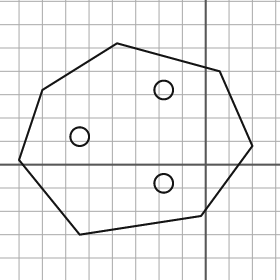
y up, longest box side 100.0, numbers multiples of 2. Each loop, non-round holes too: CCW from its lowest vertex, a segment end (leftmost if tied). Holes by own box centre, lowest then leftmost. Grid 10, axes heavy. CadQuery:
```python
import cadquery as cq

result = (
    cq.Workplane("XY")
    .moveTo(-54.0, -30.0)
    .lineTo(-2.0, -22.0)
    .lineTo(20.0, 8.0)
    .lineTo(6.0, 40.0)
    .lineTo(-38.0, 52.0)
    .lineTo(-70.0, 32.0)
    .lineTo(-80.0, 2.0)
    .close()
    .moveTo(-18.0, -8.0)
    .circle(4.0)
    .moveTo(-54.0, 12.0)
    .circle(4.0)
    .moveTo(-18.0, 32.0)
    .circle(4.0)
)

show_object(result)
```